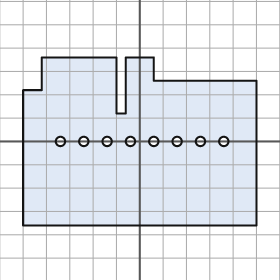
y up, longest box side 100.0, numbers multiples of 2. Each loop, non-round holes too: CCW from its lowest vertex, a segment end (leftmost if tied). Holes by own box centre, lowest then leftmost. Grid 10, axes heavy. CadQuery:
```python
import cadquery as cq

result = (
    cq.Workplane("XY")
    .moveTo(-50.0, -36.0)
    .lineTo(50.0, -36.0)
    .lineTo(50.0, 26.0)
    .lineTo(6.0, 26.0)
    .lineTo(6.0, 36.0)
    .lineTo(-6.0, 36.0)
    .lineTo(-6.0, 12.0)
    .lineTo(-10.0, 12.0)
    .lineTo(-10.0, 36.0)
    .lineTo(-42.0, 36.0)
    .lineTo(-42.0, 22.0)
    .lineTo(-50.0, 22.0)
    .close()
    .moveTo(-34.0, 0.0)
    .circle(2.0)
    .moveTo(-24.0, 0.0)
    .circle(2.0)
    .moveTo(-14.0, 0.0)
    .circle(2.0)
    .moveTo(-4.0, 0.0)
    .circle(2.0)
    .moveTo(6.0, 0.0)
    .circle(2.0)
    .moveTo(16.0, 0.0)
    .circle(2.0)
    .moveTo(26.0, 0.0)
    .circle(2.0)
    .moveTo(36.0, 0.0)
    .circle(2.0)
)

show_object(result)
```